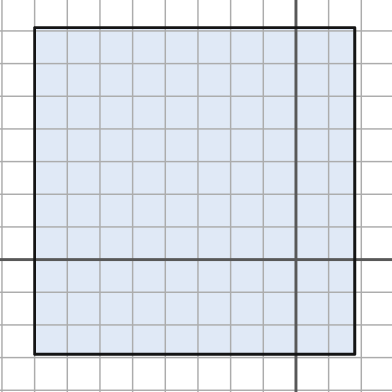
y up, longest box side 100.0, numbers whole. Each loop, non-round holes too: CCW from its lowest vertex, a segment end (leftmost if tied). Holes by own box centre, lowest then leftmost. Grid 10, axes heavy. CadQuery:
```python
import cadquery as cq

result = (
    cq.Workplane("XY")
    .moveTo(-80.0, -29.0)
    .lineTo(18.0, -29.0)
    .lineTo(18.0, 71.0)
    .lineTo(-80.0, 71.0)
    .close()
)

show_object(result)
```